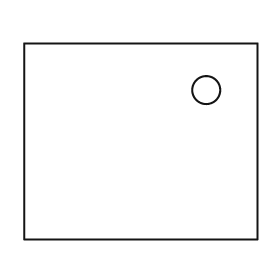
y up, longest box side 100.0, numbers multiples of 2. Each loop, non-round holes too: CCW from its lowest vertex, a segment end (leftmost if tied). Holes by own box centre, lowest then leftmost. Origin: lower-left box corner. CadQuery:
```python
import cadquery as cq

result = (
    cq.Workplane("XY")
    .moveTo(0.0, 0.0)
    .lineTo(100.0, 0.0)
    .lineTo(100.0, 84.0)
    .lineTo(0.0, 84.0)
    .close()
    .moveTo(78.0, 64.0)
    .circle(6.0)
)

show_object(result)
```